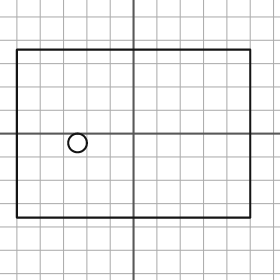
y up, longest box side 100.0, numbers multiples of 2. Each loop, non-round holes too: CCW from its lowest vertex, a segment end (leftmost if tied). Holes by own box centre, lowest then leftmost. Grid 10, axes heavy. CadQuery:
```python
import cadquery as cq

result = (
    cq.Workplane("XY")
    .moveTo(-50.0, -36.0)
    .lineTo(50.0, -36.0)
    .lineTo(50.0, 36.0)
    .lineTo(-50.0, 36.0)
    .close()
    .moveTo(-24.0, -4.0)
    .circle(4.0)
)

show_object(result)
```